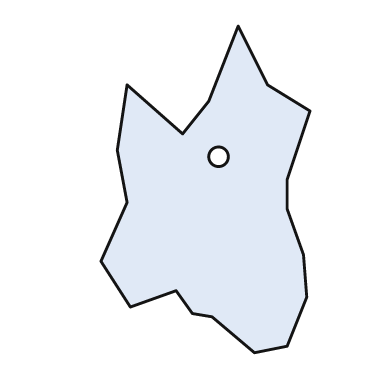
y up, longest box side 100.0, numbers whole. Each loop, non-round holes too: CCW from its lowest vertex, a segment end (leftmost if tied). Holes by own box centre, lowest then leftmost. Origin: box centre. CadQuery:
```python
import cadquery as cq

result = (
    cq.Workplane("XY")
    .moveTo(15.0, -50.0)
    .lineTo(25.0, -48.0)
    .lineTo(31.0, -33.0)
    .lineTo(30.0, -20.0)
    .lineTo(25.0, -6.0)
    .lineTo(25.0, 3.0)
    .lineTo(32.0, 24.0)
    .lineTo(19.0, 32.0)
    .lineTo(10.0, 50.0)
    .lineTo(1.0, 27.0)
    .lineTo(-7.0, 17.0)
    .lineTo(-24.0, 32.0)
    .lineTo(-27.0, 12.0)
    .lineTo(-24.0, -4.0)
    .lineTo(-32.0, -22.0)
    .lineTo(-23.0, -36.0)
    .lineTo(-9.0, -31.0)
    .lineTo(-4.0, -38.0)
    .lineTo(2.0, -39.0)
    .close()
    .moveTo(4.0, 10.0)
    .circle(3.0)
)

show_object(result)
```